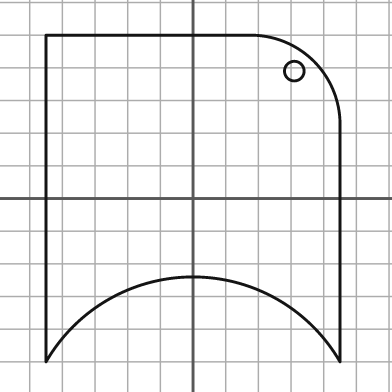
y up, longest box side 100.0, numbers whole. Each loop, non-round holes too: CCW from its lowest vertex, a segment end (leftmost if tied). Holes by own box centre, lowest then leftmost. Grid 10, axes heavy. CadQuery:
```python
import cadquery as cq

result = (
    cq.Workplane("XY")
    .moveTo(-45.0, -50.0)
    .threePointArc((0.0, -24.0), (45.0, -50.0))
    .lineTo(45.0, 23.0)
    .threePointArc((37.0, 42.0), (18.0, 50.0))
    .lineTo(-45.0, 50.0)
    .close()
    .moveTo(31.0, 39.0)
    .circle(3.0)
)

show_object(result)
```